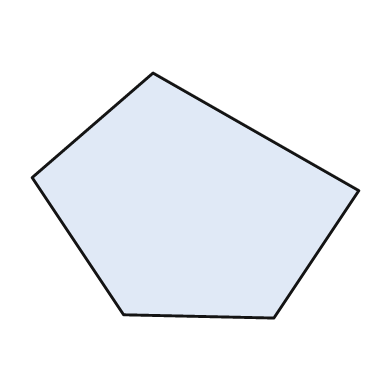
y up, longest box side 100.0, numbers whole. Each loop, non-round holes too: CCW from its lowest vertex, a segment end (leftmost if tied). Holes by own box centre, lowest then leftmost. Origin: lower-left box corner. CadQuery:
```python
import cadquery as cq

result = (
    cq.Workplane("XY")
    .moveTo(74.0, 0.0)
    .lineTo(100.0, 39.0)
    .lineTo(37.0, 75.0)
    .lineTo(0.0, 43.0)
    .lineTo(28.0, 1.0)
    .close()
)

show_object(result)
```